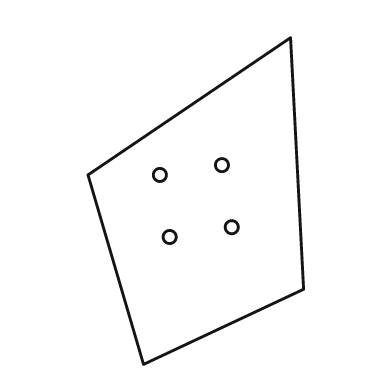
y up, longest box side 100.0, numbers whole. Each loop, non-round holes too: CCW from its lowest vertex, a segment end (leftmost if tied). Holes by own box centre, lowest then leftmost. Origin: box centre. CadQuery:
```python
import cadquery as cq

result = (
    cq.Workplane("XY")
    .moveTo(-16.0, -50.0)
    .lineTo(33.0, -27.0)
    .lineTo(29.0, 50.0)
    .lineTo(-33.0, 8.0)
    .close()
    .moveTo(-8.0, -11.0)
    .circle(2.0)
    .moveTo(11.0, -8.0)
    .circle(2.0)
    .moveTo(-11.0, 8.0)
    .circle(2.0)
    .moveTo(8.0, 11.0)
    .circle(2.0)
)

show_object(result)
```